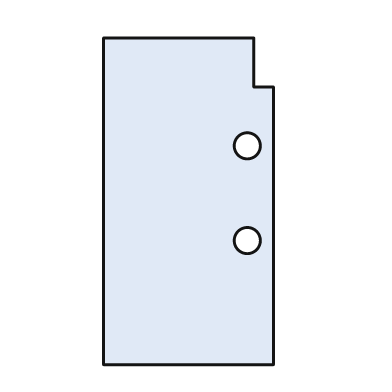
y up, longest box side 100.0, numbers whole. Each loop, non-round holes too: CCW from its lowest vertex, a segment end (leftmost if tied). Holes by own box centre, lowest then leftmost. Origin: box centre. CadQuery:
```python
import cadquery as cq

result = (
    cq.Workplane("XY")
    .moveTo(-26.0, -50.0)
    .lineTo(26.0, -50.0)
    .lineTo(26.0, 35.0)
    .lineTo(20.0, 35.0)
    .lineTo(20.0, 50.0)
    .lineTo(-26.0, 50.0)
    .close()
    .moveTo(18.0, -12.0)
    .circle(4.0)
    .moveTo(18.0, 17.0)
    .circle(4.0)
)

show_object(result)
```